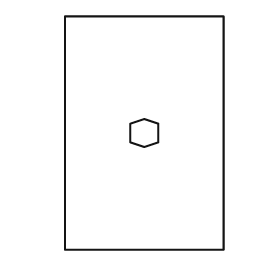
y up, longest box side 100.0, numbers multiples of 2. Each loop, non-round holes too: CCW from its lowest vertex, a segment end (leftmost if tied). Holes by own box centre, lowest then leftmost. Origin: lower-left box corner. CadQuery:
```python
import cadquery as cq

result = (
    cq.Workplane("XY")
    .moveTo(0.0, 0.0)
    .lineTo(68.0, 0.0)
    .lineTo(68.0, 100.0)
    .lineTo(0.0, 100.0)
    .close()
    .moveTo(34.0, 44.0)
    .lineTo(40.0, 46.0)
    .lineTo(40.0, 54.0)
    .lineTo(34.0, 56.0)
    .lineTo(28.0, 54.0)
    .lineTo(28.0, 46.0)
    .close()
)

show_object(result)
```